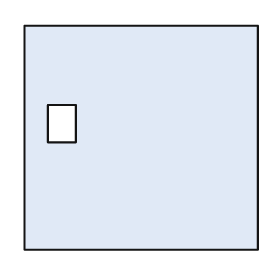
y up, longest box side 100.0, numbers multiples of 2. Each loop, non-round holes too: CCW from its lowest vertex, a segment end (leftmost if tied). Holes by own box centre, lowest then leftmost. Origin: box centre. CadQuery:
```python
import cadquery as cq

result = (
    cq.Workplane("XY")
    .moveTo(-50.0, -48.0)
    .lineTo(50.0, -48.0)
    .lineTo(50.0, 48.0)
    .lineTo(-50.0, 48.0)
    .close()
    .moveTo(-40.0, -2.0)
    .lineTo(-28.0, -2.0)
    .lineTo(-28.0, 14.0)
    .lineTo(-40.0, 14.0)
    .close()
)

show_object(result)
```